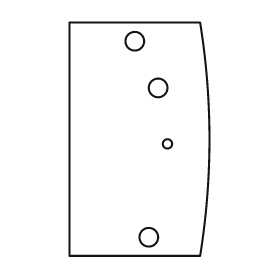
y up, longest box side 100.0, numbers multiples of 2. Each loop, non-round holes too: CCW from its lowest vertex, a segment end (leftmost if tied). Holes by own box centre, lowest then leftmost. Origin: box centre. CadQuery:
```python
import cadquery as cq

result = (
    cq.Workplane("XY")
    .moveTo(-30.0, -50.0)
    .lineTo(26.0, -50.0)
    .threePointArc((30.0, 0.0), (26.0, 50.0))
    .lineTo(-30.0, 50.0)
    .close()
    .moveTo(4.0, -42.0)
    .circle(4.0)
    .moveTo(12.0, -2.0)
    .circle(2.0)
    .moveTo(8.0, 22.0)
    .circle(4.0)
    .moveTo(-2.0, 42.0)
    .circle(4.0)
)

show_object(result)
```